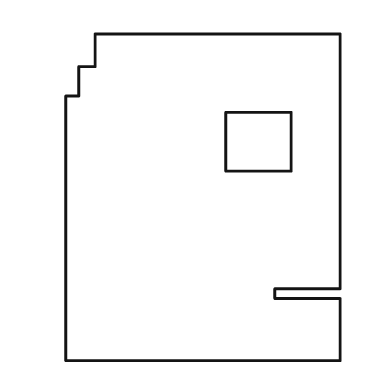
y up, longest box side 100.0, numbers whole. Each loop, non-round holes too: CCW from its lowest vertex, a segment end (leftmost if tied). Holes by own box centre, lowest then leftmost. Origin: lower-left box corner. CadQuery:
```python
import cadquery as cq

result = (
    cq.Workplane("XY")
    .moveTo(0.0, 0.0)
    .lineTo(84.0, 0.0)
    .lineTo(84.0, 19.0)
    .lineTo(64.0, 19.0)
    .lineTo(64.0, 22.0)
    .lineTo(84.0, 22.0)
    .lineTo(84.0, 100.0)
    .lineTo(9.0, 100.0)
    .lineTo(9.0, 90.0)
    .lineTo(4.0, 90.0)
    .lineTo(4.0, 81.0)
    .lineTo(0.0, 81.0)
    .close()
    .moveTo(49.0, 58.0)
    .lineTo(69.0, 58.0)
    .lineTo(69.0, 76.0)
    .lineTo(49.0, 76.0)
    .close()
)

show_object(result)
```